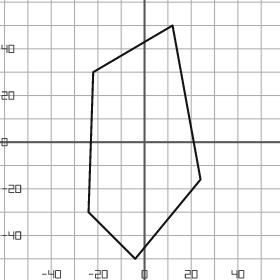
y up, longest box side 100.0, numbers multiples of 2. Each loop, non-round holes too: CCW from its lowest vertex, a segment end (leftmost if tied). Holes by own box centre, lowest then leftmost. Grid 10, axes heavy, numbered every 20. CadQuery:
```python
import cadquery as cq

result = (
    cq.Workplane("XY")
    .moveTo(-4.0, -50.0)
    .lineTo(24.0, -16.0)
    .lineTo(12.0, 50.0)
    .lineTo(-22.0, 30.0)
    .lineTo(-24.0, -30.0)
    .close()
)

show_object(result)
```